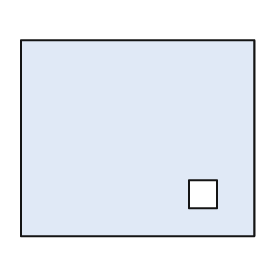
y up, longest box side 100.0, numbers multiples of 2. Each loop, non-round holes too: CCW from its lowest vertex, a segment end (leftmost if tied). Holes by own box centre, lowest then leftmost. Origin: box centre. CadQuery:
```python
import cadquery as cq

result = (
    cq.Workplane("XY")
    .moveTo(-50.0, -42.0)
    .lineTo(50.0, -42.0)
    .lineTo(50.0, 42.0)
    .lineTo(-50.0, 42.0)
    .close()
    .moveTo(22.0, -30.0)
    .lineTo(34.0, -30.0)
    .lineTo(34.0, -18.0)
    .lineTo(22.0, -18.0)
    .close()
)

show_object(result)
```